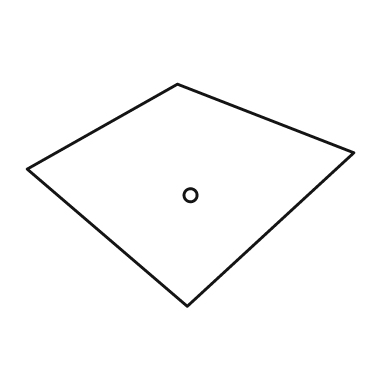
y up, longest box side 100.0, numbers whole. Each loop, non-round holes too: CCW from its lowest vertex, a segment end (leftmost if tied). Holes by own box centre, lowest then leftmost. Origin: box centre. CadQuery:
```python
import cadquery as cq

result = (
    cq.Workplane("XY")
    .moveTo(-1.0, -34.0)
    .lineTo(50.0, 13.0)
    .lineTo(-4.0, 34.0)
    .lineTo(-50.0, 8.0)
    .close()
    .moveTo(0.0, 0.0)
    .circle(2.0)
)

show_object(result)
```